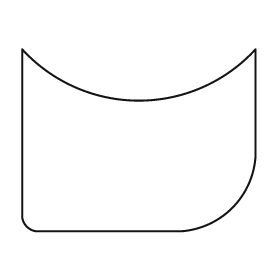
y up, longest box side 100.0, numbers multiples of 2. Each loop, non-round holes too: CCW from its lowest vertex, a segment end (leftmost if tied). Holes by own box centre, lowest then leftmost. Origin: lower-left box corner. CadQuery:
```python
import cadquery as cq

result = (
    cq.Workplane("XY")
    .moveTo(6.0, 0.0)
    .lineTo(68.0, 0.0)
    .threePointArc((90.0, 10.0), (100.0, 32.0))
    .lineTo(100.0, 78.0)
    .threePointArc((50.0, 56.0), (0.0, 78.0))
    .lineTo(0.0, 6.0)
    .threePointArc((2.0, 2.0), (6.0, 0.0))
    .close()
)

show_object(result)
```